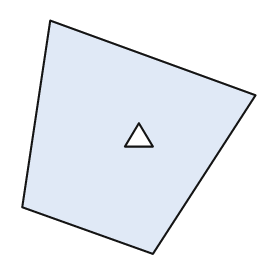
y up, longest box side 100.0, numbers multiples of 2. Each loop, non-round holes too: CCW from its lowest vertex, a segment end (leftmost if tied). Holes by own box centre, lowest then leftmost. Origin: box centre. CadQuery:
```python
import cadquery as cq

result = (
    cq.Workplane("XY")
    .moveTo(6.0, -50.0)
    .lineTo(50.0, 18.0)
    .lineTo(-38.0, 50.0)
    .lineTo(-50.0, -30.0)
    .close()
    .moveTo(-6.0, -4.0)
    .lineTo(6.0, -4.0)
    .lineTo(0.0, 6.0)
    .close()
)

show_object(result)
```